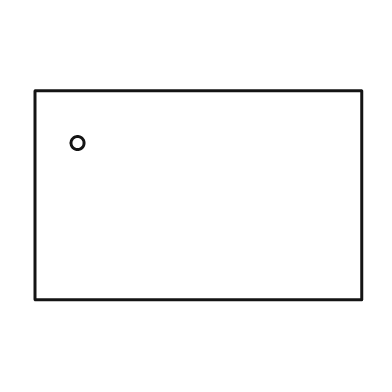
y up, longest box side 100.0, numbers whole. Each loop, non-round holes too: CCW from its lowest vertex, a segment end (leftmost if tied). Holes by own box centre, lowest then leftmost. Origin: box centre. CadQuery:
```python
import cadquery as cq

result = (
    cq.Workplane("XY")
    .moveTo(-50.0, -32.0)
    .lineTo(50.0, -32.0)
    .lineTo(50.0, 32.0)
    .lineTo(-50.0, 32.0)
    .close()
    .moveTo(-37.0, 16.0)
    .circle(2.0)
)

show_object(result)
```